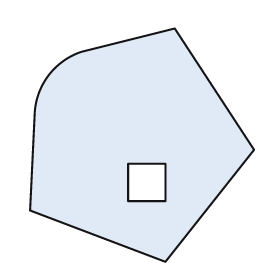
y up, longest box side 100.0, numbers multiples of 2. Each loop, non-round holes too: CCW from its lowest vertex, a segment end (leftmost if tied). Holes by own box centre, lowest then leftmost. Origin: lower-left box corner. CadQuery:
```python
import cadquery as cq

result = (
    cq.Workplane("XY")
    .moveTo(58.0, 0.0)
    .lineTo(96.0, 48.0)
    .lineTo(62.0, 100.0)
    .lineTo(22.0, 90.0)
    .threePointArc((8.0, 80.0), (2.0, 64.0))
    .lineTo(0.0, 22.0)
    .close()
    .moveTo(42.0, 26.0)
    .lineTo(58.0, 26.0)
    .lineTo(58.0, 42.0)
    .lineTo(42.0, 42.0)
    .close()
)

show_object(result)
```